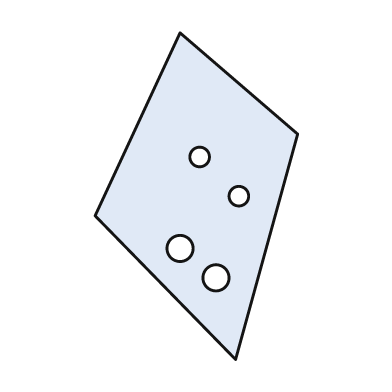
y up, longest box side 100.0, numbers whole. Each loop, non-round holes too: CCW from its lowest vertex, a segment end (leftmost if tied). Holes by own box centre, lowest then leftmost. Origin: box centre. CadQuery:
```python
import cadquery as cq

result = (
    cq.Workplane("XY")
    .moveTo(12.0, -50.0)
    .lineTo(31.0, 19.0)
    .lineTo(-5.0, 50.0)
    .lineTo(-31.0, -6.0)
    .close()
    .moveTo(6.0, -25.0)
    .circle(4.0)
    .moveTo(-5.0, -16.0)
    .circle(4.0)
    .moveTo(13.0, 0.0)
    .circle(3.0)
    .moveTo(1.0, 12.0)
    .circle(3.0)
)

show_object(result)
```